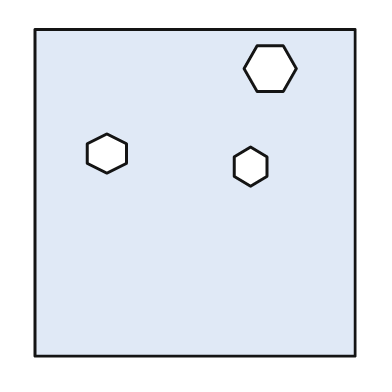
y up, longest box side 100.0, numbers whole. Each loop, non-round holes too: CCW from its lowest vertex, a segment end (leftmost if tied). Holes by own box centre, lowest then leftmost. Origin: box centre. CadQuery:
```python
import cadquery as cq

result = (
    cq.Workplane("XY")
    .moveTo(-49.0, -50.0)
    .lineTo(49.0, -50.0)
    .lineTo(49.0, 50.0)
    .lineTo(-49.0, 50.0)
    .close()
    .moveTo(17.0, 2.0)
    .lineTo(22.0, 5.0)
    .lineTo(22.0, 11.0)
    .lineTo(17.0, 14.0)
    .lineTo(12.0, 11.0)
    .lineTo(12.0, 5.0)
    .close()
    .moveTo(-27.0, 6.0)
    .lineTo(-21.0, 9.0)
    .lineTo(-21.0, 15.0)
    .lineTo(-27.0, 18.0)
    .lineTo(-33.0, 15.0)
    .lineTo(-33.0, 9.0)
    .close()
    .moveTo(19.0, 31.0)
    .lineTo(27.0, 31.0)
    .lineTo(31.0, 38.0)
    .lineTo(27.0, 45.0)
    .lineTo(19.0, 45.0)
    .lineTo(15.0, 38.0)
    .close()
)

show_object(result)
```